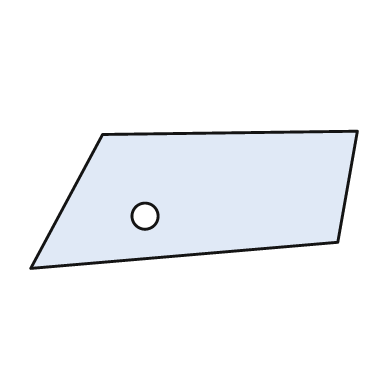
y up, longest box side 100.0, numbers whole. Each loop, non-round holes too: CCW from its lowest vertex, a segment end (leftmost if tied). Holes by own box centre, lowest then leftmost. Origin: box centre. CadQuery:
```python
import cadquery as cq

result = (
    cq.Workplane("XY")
    .moveTo(-50.0, -21.0)
    .lineTo(44.0, -13.0)
    .lineTo(50.0, 21.0)
    .lineTo(-28.0, 20.0)
    .close()
    .moveTo(-15.0, -5.0)
    .circle(4.0)
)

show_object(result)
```